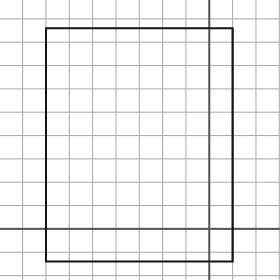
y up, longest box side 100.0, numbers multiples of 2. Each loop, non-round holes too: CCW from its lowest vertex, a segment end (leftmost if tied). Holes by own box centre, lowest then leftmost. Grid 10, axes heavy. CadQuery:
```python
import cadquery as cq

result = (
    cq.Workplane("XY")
    .moveTo(-70.0, -14.0)
    .lineTo(10.0, -14.0)
    .lineTo(10.0, 86.0)
    .lineTo(-70.0, 86.0)
    .close()
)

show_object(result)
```